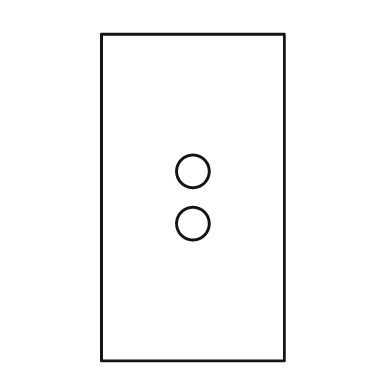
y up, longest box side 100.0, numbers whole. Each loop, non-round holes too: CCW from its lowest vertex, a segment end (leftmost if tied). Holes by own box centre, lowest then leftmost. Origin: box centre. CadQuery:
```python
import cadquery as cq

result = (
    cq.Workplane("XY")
    .moveTo(-28.0, -50.0)
    .lineTo(28.0, -50.0)
    .lineTo(28.0, 50.0)
    .lineTo(-28.0, 50.0)
    .close()
    .moveTo(0.0, -8.0)
    .circle(5.0)
    .moveTo(0.0, 8.0)
    .circle(5.0)
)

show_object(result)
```